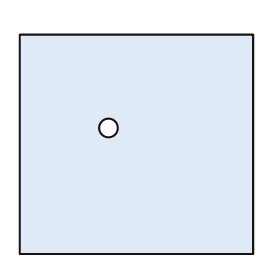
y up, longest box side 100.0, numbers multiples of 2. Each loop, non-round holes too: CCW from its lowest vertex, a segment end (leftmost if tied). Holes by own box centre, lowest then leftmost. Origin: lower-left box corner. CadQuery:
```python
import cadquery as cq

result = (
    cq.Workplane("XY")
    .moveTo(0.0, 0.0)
    .lineTo(100.0, 0.0)
    .lineTo(100.0, 94.0)
    .lineTo(0.0, 94.0)
    .close()
    .moveTo(38.0, 54.0)
    .circle(4.0)
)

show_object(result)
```